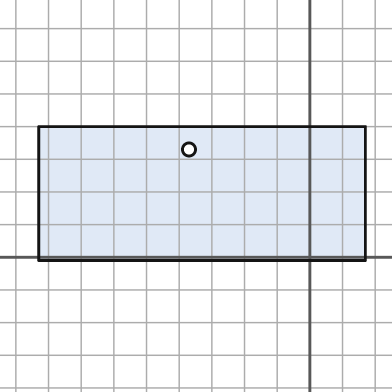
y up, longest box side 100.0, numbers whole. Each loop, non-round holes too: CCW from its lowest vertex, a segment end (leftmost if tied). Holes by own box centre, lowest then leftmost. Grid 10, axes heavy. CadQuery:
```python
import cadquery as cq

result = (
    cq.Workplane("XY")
    .moveTo(-83.0, -1.0)
    .lineTo(17.0, -1.0)
    .lineTo(17.0, 40.0)
    .lineTo(-83.0, 40.0)
    .close()
    .moveTo(-37.0, 33.0)
    .circle(2.0)
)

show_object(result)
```